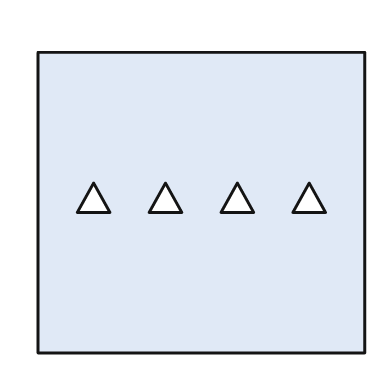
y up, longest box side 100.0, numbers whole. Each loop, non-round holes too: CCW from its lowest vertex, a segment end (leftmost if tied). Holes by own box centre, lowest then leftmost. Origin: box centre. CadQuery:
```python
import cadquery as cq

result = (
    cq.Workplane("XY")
    .moveTo(-50.0, -46.0)
    .lineTo(50.0, -46.0)
    .lineTo(50.0, 46.0)
    .lineTo(-50.0, 46.0)
    .close()
    .moveTo(-38.0, -3.0)
    .lineTo(-28.0, -3.0)
    .lineTo(-33.0, 6.0)
    .close()
    .moveTo(-16.0, -3.0)
    .lineTo(-6.0, -3.0)
    .lineTo(-11.0, 6.0)
    .close()
    .moveTo(6.0, -3.0)
    .lineTo(16.0, -3.0)
    .lineTo(11.0, 6.0)
    .close()
    .moveTo(28.0, -3.0)
    .lineTo(38.0, -3.0)
    .lineTo(33.0, 6.0)
    .close()
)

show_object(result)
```